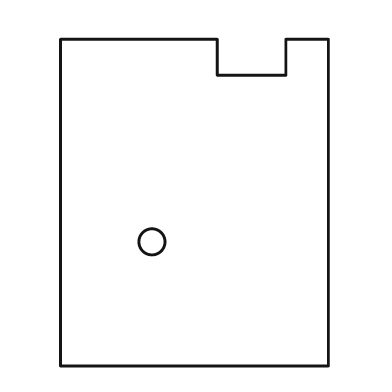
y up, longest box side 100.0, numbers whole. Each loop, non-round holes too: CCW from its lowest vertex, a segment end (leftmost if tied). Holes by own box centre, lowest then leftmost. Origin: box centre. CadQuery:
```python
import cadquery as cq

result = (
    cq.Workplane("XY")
    .moveTo(-41.0, -50.0)
    .lineTo(41.0, -50.0)
    .lineTo(41.0, 50.0)
    .lineTo(28.0, 50.0)
    .lineTo(28.0, 39.0)
    .lineTo(7.0, 39.0)
    .lineTo(7.0, 50.0)
    .lineTo(-41.0, 50.0)
    .close()
    .moveTo(-13.0, -12.0)
    .circle(4.0)
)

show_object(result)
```